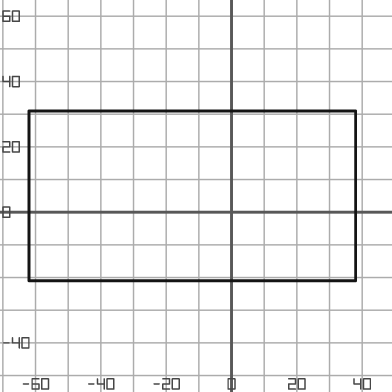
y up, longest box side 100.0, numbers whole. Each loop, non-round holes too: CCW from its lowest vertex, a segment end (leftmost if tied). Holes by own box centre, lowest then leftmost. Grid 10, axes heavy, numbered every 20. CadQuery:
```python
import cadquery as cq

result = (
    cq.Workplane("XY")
    .moveTo(-62.0, -21.0)
    .lineTo(38.0, -21.0)
    .lineTo(38.0, 31.0)
    .lineTo(-62.0, 31.0)
    .close()
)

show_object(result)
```